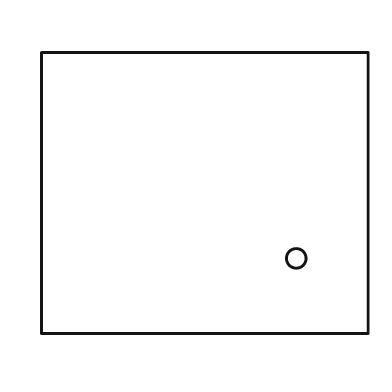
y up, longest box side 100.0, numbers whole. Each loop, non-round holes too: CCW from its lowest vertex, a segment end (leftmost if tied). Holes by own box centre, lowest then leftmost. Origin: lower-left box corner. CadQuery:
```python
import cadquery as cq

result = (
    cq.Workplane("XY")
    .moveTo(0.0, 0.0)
    .lineTo(100.0, 0.0)
    .lineTo(100.0, 86.0)
    .lineTo(0.0, 86.0)
    .close()
    .moveTo(78.0, 23.0)
    .circle(3.0)
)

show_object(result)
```